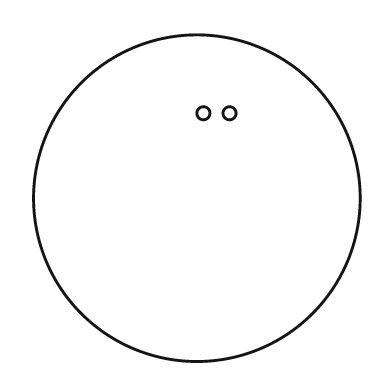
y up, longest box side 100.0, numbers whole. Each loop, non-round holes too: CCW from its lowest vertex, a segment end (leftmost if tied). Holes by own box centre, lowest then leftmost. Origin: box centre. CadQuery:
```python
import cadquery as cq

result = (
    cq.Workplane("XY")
    .moveTo(0.0, 0.0)
    .circle(50.0)
    .moveTo(2.0, 26.0)
    .circle(2.0)
    .moveTo(10.0, 26.0)
    .circle(2.0)
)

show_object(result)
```